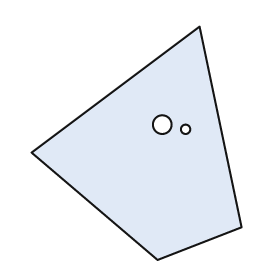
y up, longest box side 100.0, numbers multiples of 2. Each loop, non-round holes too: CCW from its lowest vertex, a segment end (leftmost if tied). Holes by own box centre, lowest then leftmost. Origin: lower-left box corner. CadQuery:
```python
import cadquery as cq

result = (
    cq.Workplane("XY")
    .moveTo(54.0, 0.0)
    .lineTo(90.0, 14.0)
    .lineTo(72.0, 100.0)
    .lineTo(0.0, 46.0)
    .close()
    .moveTo(66.0, 56.0)
    .circle(2.0)
    .moveTo(56.0, 58.0)
    .circle(4.0)
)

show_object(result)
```